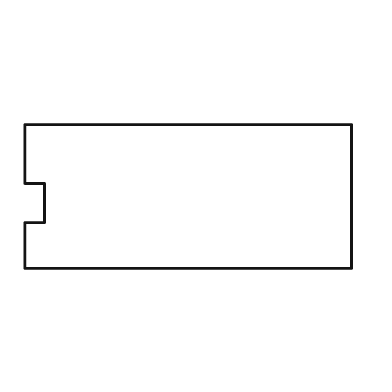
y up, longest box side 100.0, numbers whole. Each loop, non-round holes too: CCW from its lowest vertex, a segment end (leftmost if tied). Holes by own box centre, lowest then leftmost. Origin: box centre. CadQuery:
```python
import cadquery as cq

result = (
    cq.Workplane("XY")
    .moveTo(-50.0, -22.0)
    .lineTo(50.0, -22.0)
    .lineTo(50.0, 22.0)
    .lineTo(-50.0, 22.0)
    .lineTo(-50.0, 4.0)
    .lineTo(-44.0, 4.0)
    .lineTo(-44.0, -8.0)
    .lineTo(-50.0, -8.0)
    .close()
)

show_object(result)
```